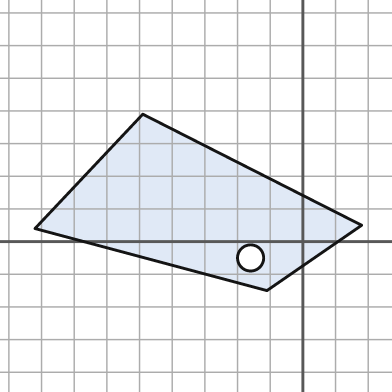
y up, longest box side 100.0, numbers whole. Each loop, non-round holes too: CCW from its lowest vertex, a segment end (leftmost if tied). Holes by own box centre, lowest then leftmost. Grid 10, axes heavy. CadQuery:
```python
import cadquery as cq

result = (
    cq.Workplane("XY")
    .moveTo(-11.0, -15.0)
    .lineTo(18.0, 5.0)
    .lineTo(-49.0, 39.0)
    .lineTo(-82.0, 4.0)
    .close()
    .moveTo(-16.0, -5.0)
    .circle(4.0)
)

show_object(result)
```